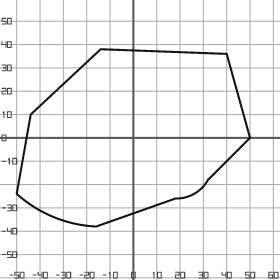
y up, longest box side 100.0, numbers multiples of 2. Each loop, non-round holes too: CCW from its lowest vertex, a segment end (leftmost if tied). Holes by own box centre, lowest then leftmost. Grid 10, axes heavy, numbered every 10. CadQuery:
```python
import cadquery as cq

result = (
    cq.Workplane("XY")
    .moveTo(-16.0, -38.0)
    .lineTo(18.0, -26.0)
    .threePointArc((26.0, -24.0), (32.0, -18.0))
    .lineTo(50.0, 0.0)
    .lineTo(40.0, 36.0)
    .lineTo(-14.0, 38.0)
    .lineTo(-44.0, 10.0)
    .lineTo(-50.0, -24.0)
    .threePointArc((-34.0, -34.0), (-16.0, -38.0))
    .close()
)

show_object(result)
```